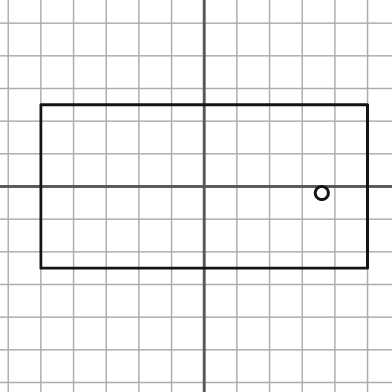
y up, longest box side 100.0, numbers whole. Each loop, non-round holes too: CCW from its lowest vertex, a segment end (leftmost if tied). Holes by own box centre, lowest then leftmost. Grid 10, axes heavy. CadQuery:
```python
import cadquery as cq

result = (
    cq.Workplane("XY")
    .moveTo(-50.0, -25.0)
    .lineTo(50.0, -25.0)
    .lineTo(50.0, 25.0)
    .lineTo(-50.0, 25.0)
    .close()
    .moveTo(36.0, -2.0)
    .circle(2.0)
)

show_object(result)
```